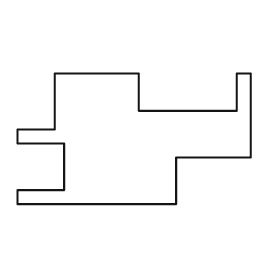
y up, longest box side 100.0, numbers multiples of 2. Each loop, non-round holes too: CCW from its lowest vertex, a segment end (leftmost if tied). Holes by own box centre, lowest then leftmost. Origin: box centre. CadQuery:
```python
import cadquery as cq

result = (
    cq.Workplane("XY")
    .moveTo(-50.0, -28.0)
    .lineTo(18.0, -28.0)
    .lineTo(18.0, -8.0)
    .lineTo(50.0, -8.0)
    .lineTo(50.0, 28.0)
    .lineTo(44.0, 28.0)
    .lineTo(44.0, 12.0)
    .lineTo(2.0, 12.0)
    .lineTo(2.0, 28.0)
    .lineTo(-34.0, 28.0)
    .lineTo(-34.0, 4.0)
    .lineTo(-50.0, 4.0)
    .lineTo(-50.0, -2.0)
    .lineTo(-30.0, -2.0)
    .lineTo(-30.0, -22.0)
    .lineTo(-50.0, -22.0)
    .close()
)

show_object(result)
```